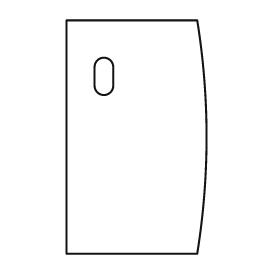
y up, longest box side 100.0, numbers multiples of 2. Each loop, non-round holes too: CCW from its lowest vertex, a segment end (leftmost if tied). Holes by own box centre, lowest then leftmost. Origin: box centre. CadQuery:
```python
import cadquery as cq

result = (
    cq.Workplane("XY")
    .moveTo(-30.0, -50.0)
    .lineTo(26.0, -50.0)
    .threePointArc((30.0, 0.0), (26.0, 50.0))
    .lineTo(-30.0, 50.0)
    .close()
    .moveTo(-18.0, 22.0)
    .threePointArc((-14.0, 18.0), (-10.0, 22.0))
    .lineTo(-10.0, 30.0)
    .threePointArc((-14.0, 34.0), (-18.0, 30.0))
    .close()
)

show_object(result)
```